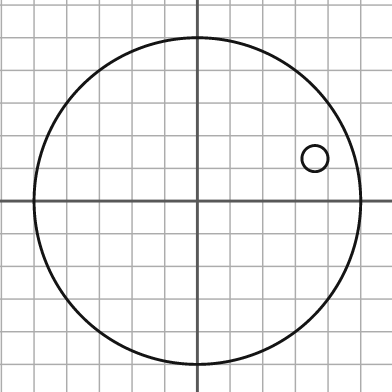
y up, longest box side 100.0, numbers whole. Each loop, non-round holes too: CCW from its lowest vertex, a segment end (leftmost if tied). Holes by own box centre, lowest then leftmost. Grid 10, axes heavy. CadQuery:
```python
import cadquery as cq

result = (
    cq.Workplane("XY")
    .moveTo(0.0, 0.0)
    .circle(50.0)
    .moveTo(36.0, 13.0)
    .circle(4.0)
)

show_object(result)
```